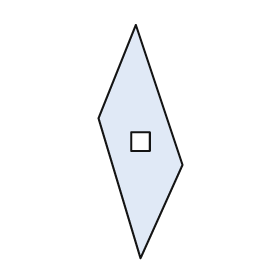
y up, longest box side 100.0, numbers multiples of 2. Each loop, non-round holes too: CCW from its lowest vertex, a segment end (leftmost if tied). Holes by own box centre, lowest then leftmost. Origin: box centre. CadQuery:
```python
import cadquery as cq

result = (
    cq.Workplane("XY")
    .moveTo(0.0, -50.0)
    .lineTo(18.0, -10.0)
    .lineTo(-2.0, 50.0)
    .lineTo(-18.0, 10.0)
    .close()
    .moveTo(-4.0, -4.0)
    .lineTo(4.0, -4.0)
    .lineTo(4.0, 4.0)
    .lineTo(-4.0, 4.0)
    .close()
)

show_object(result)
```